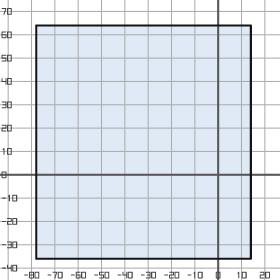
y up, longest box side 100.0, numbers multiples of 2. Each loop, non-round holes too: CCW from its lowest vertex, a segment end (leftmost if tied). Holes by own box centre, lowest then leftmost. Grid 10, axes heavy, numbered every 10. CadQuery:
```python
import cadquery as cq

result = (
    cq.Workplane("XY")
    .moveTo(-78.0, -36.0)
    .lineTo(14.0, -36.0)
    .lineTo(14.0, 64.0)
    .lineTo(-78.0, 64.0)
    .close()
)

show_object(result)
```